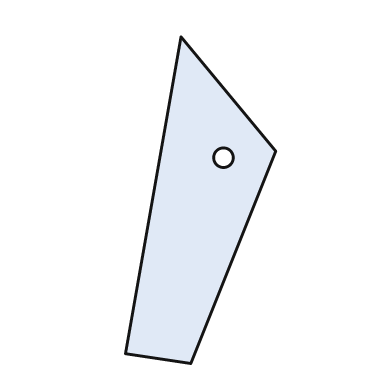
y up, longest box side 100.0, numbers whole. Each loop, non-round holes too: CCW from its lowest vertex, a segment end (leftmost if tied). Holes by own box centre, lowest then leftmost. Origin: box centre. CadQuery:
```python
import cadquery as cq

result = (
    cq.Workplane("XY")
    .moveTo(-3.0, -50.0)
    .lineTo(23.0, 15.0)
    .lineTo(-6.0, 50.0)
    .lineTo(-23.0, -47.0)
    .close()
    .moveTo(7.0, 13.0)
    .circle(3.0)
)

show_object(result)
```